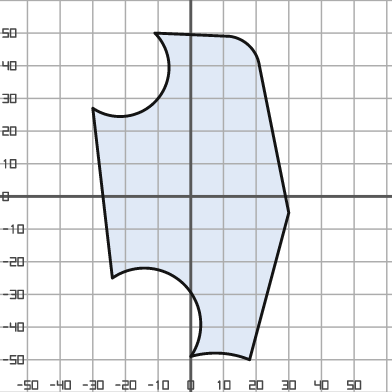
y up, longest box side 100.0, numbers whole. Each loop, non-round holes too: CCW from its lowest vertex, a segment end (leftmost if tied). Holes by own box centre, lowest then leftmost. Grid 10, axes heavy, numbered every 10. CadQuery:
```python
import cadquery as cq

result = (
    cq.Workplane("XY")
    .moveTo(18.0, -50.0)
    .lineTo(30.0, -5.0)
    .lineTo(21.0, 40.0)
    .threePointArc((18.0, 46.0), (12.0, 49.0))
    .lineTo(-11.0, 50.0)
    .threePointArc((-10.0, 30.0), (-30.0, 27.0))
    .lineTo(-24.0, -25.0)
    .threePointArc((-2.0, -27.0), (0.0, -49.0))
    .threePointArc((9.0, -48.0), (18.0, -50.0))
    .close()
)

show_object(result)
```